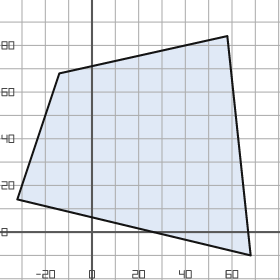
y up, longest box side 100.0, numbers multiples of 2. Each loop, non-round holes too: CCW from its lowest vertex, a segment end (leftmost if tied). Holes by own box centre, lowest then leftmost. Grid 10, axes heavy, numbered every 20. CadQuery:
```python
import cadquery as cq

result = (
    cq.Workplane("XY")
    .moveTo(68.0, -10.0)
    .lineTo(58.0, 84.0)
    .lineTo(-14.0, 68.0)
    .lineTo(-32.0, 14.0)
    .close()
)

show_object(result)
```